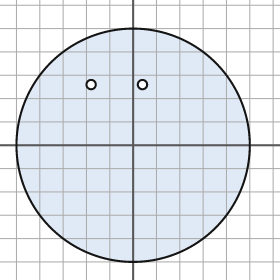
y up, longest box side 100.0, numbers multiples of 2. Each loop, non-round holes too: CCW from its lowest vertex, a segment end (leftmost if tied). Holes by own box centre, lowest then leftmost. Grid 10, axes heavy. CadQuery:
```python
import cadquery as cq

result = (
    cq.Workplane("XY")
    .moveTo(0.0, 0.0)
    .circle(50.0)
    .moveTo(-18.0, 26.0)
    .circle(2.0)
    .moveTo(4.0, 26.0)
    .circle(2.0)
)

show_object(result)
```